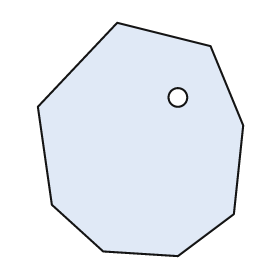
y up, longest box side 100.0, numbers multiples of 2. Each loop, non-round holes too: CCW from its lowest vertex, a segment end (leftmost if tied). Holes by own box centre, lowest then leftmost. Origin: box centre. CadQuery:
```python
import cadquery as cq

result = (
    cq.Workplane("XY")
    .moveTo(16.0, -50.0)
    .lineTo(40.0, -32.0)
    .lineTo(44.0, 6.0)
    .lineTo(30.0, 40.0)
    .lineTo(-10.0, 50.0)
    .lineTo(-44.0, 14.0)
    .lineTo(-38.0, -28.0)
    .lineTo(-16.0, -48.0)
    .close()
    .moveTo(16.0, 18.0)
    .circle(4.0)
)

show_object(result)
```